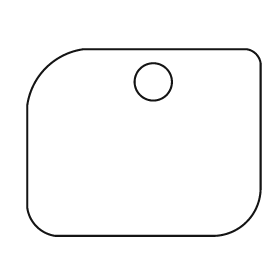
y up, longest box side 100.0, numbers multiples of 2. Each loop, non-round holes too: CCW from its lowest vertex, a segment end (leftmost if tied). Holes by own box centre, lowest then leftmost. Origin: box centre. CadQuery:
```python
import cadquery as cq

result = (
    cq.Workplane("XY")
    .moveTo(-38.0, -40.0)
    .lineTo(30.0, -40.0)
    .threePointArc((44.0, -34.0), (50.0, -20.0))
    .lineTo(50.0, 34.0)
    .threePointArc((48.0, 38.0), (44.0, 40.0))
    .lineTo(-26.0, 40.0)
    .threePointArc((-42.0, 32.0), (-50.0, 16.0))
    .lineTo(-50.0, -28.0)
    .threePointArc((-46.0, -36.0), (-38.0, -40.0))
    .close()
    .moveTo(4.0, 26.0)
    .circle(8.0)
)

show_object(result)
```